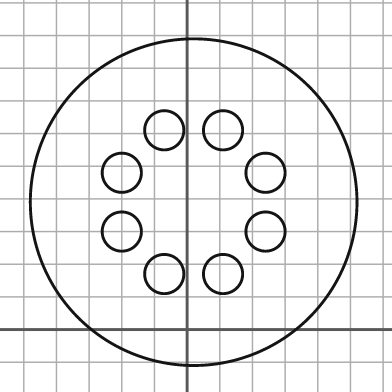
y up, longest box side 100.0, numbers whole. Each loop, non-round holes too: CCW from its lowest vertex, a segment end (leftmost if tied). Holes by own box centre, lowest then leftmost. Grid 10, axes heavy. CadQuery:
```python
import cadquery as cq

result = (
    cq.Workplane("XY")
    .moveTo(2.0, 39.0)
    .circle(50.0)
    .moveTo(-7.0, 17.0)
    .circle(6.0)
    .moveTo(11.0, 17.0)
    .circle(6.0)
    .moveTo(-20.0, 30.0)
    .circle(6.0)
    .moveTo(24.0, 30.0)
    .circle(6.0)
    .moveTo(-20.0, 48.0)
    .circle(6.0)
    .moveTo(24.0, 48.0)
    .circle(6.0)
    .moveTo(-7.0, 61.0)
    .circle(6.0)
    .moveTo(11.0, 61.0)
    .circle(6.0)
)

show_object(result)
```